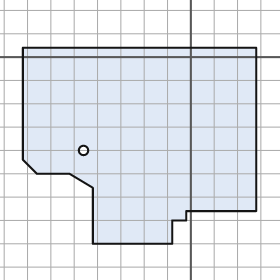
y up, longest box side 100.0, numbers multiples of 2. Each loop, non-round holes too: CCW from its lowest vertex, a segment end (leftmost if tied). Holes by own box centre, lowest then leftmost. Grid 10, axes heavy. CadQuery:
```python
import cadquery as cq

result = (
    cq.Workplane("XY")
    .moveTo(-42.0, -80.0)
    .lineTo(-8.0, -80.0)
    .lineTo(-8.0, -70.0)
    .lineTo(-2.0, -70.0)
    .lineTo(-2.0, -66.0)
    .lineTo(28.0, -66.0)
    .lineTo(28.0, 4.0)
    .lineTo(-72.0, 4.0)
    .lineTo(-72.0, -44.0)
    .lineTo(-66.0, -50.0)
    .lineTo(-52.0, -50.0)
    .lineTo(-42.0, -56.0)
    .close()
    .moveTo(-46.0, -40.0)
    .circle(2.0)
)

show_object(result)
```